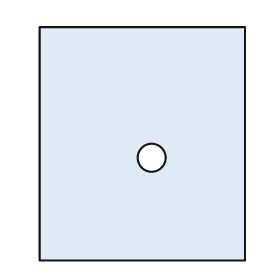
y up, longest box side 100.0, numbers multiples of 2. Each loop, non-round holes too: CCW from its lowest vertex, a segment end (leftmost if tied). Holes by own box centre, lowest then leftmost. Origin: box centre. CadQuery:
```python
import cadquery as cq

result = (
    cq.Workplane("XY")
    .moveTo(-44.0, -50.0)
    .lineTo(44.0, -50.0)
    .lineTo(44.0, 50.0)
    .lineTo(-44.0, 50.0)
    .close()
    .moveTo(4.0, -6.0)
    .circle(6.0)
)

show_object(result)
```